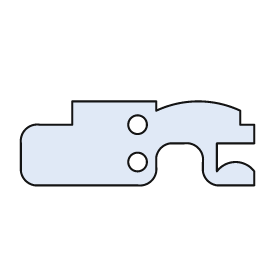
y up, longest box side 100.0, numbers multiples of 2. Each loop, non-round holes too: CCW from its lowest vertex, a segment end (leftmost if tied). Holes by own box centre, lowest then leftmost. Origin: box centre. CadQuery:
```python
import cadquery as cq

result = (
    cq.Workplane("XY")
    .moveTo(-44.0, -18.0)
    .lineTo(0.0, -18.0)
    .threePointArc((6.0, -16.0), (8.0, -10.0))
    .lineTo(8.0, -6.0)
    .threePointArc((10.0, -2.0), (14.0, 0.0))
    .lineTo(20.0, 0.0)
    .threePointArc((26.0, -2.0), (28.0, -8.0))
    .lineTo(28.0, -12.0)
    .threePointArc((30.0, -16.0), (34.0, -18.0))
    .lineTo(50.0, -18.0)
    .lineTo(50.0, -12.0)
    .threePointArc((42.0, -8.0), (34.0, -12.0))
    .lineTo(34.0, 0.0)
    .lineTo(50.0, 0.0)
    .lineTo(50.0, 8.0)
    .lineTo(44.0, 8.0)
    .lineTo(44.0, 14.0)
    .threePointArc((26.0, 18.0), (8.0, 14.0))
    .lineTo(8.0, 18.0)
    .lineTo(-28.0, 18.0)
    .lineTo(-28.0, 8.0)
    .lineTo(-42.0, 8.0)
    .threePointArc((-48.0, 6.0), (-50.0, 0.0))
    .lineTo(-50.0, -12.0)
    .threePointArc((-48.0, -16.0), (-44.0, -18.0))
    .close()
    .moveTo(0.0, -8.0)
    .circle(4.0)
    .moveTo(0.0, 8.0)
    .circle(4.0)
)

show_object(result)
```